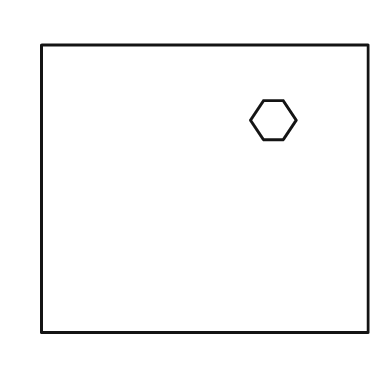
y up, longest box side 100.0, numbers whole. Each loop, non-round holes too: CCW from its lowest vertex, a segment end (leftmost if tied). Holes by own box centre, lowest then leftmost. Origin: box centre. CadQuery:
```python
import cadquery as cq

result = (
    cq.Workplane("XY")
    .moveTo(-50.0, -44.0)
    .lineTo(50.0, -44.0)
    .lineTo(50.0, 44.0)
    .lineTo(-50.0, 44.0)
    .close()
    .moveTo(18.0, 15.0)
    .lineTo(24.0, 15.0)
    .lineTo(28.0, 21.0)
    .lineTo(24.0, 27.0)
    .lineTo(18.0, 27.0)
    .lineTo(14.0, 21.0)
    .close()
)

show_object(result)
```